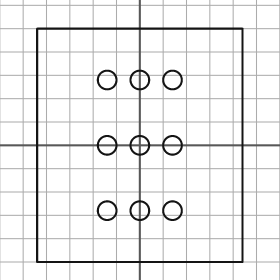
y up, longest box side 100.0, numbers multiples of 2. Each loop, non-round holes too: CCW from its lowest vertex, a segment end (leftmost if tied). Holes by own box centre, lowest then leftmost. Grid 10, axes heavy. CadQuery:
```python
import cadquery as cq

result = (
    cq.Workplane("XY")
    .moveTo(-44.0, -50.0)
    .lineTo(44.0, -50.0)
    .lineTo(44.0, 50.0)
    .lineTo(-44.0, 50.0)
    .close()
    .moveTo(-14.0, -28.0)
    .circle(4.0)
    .moveTo(0.0, -28.0)
    .circle(4.0)
    .moveTo(14.0, -28.0)
    .circle(4.0)
    .moveTo(-14.0, 0.0)
    .circle(4.0)
    .moveTo(0.0, 0.0)
    .circle(4.0)
    .moveTo(14.0, 0.0)
    .circle(4.0)
    .moveTo(-14.0, 28.0)
    .circle(4.0)
    .moveTo(0.0, 28.0)
    .circle(4.0)
    .moveTo(14.0, 28.0)
    .circle(4.0)
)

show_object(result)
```